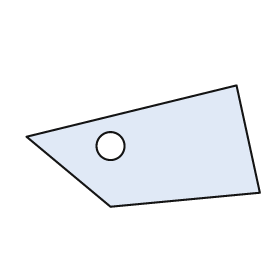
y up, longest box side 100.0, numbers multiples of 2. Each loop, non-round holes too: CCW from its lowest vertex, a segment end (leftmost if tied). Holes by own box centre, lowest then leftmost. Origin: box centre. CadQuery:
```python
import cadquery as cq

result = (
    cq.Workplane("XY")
    .moveTo(-14.0, -26.0)
    .lineTo(50.0, -20.0)
    .lineTo(40.0, 26.0)
    .lineTo(-50.0, 4.0)
    .close()
    .moveTo(-14.0, 0.0)
    .circle(6.0)
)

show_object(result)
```